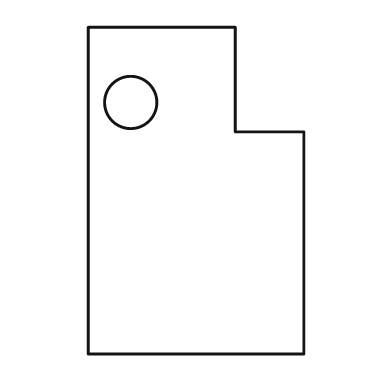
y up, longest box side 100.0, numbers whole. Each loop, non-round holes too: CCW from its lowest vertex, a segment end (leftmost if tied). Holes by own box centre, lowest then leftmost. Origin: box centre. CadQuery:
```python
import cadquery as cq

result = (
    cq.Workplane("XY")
    .moveTo(-33.0, -50.0)
    .lineTo(33.0, -50.0)
    .lineTo(33.0, 18.0)
    .lineTo(12.0, 18.0)
    .lineTo(12.0, 50.0)
    .lineTo(-33.0, 50.0)
    .close()
    .moveTo(-20.0, 27.0)
    .circle(8.0)
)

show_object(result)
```